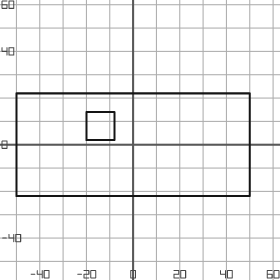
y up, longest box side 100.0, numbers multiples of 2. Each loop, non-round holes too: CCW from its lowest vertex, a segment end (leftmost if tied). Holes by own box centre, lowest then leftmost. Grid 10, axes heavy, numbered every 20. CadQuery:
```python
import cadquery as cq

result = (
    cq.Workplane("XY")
    .moveTo(-50.0, -22.0)
    .lineTo(50.0, -22.0)
    .lineTo(50.0, 22.0)
    .lineTo(-50.0, 22.0)
    .close()
    .moveTo(-20.0, 2.0)
    .lineTo(-8.0, 2.0)
    .lineTo(-8.0, 14.0)
    .lineTo(-20.0, 14.0)
    .close()
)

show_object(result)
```